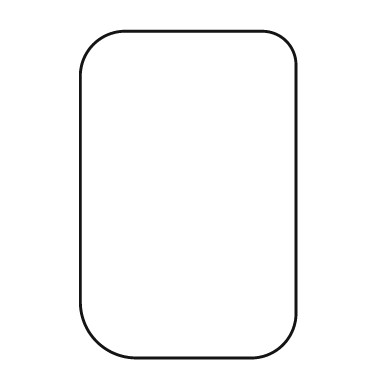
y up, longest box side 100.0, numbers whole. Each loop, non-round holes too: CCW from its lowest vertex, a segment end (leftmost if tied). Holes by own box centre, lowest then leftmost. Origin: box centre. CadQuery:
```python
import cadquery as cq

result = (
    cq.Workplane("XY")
    .moveTo(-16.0, -50.0)
    .lineTo(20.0, -50.0)
    .threePointArc((29.0, -46.0), (33.0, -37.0))
    .lineTo(33.0, 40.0)
    .threePointArc((30.0, 47.0), (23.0, 50.0))
    .lineTo(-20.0, 50.0)
    .threePointArc((-29.0, 46.0), (-33.0, 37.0))
    .lineTo(-33.0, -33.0)
    .threePointArc((-28.0, -45.0), (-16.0, -50.0))
    .close()
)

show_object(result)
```